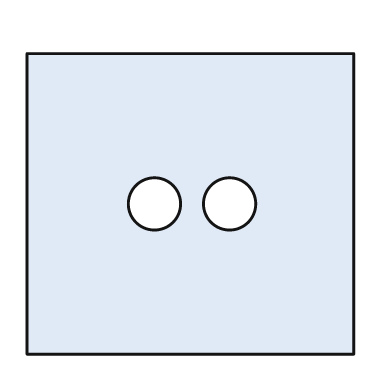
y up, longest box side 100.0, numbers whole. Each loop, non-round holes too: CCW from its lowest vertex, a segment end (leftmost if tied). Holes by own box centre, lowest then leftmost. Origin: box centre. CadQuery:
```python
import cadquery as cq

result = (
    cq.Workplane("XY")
    .moveTo(-50.0, -46.0)
    .lineTo(50.0, -46.0)
    .lineTo(50.0, 46.0)
    .lineTo(-50.0, 46.0)
    .close()
    .moveTo(-11.0, 0.0)
    .circle(8.0)
    .moveTo(12.0, 0.0)
    .circle(8.0)
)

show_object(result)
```